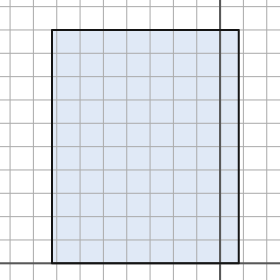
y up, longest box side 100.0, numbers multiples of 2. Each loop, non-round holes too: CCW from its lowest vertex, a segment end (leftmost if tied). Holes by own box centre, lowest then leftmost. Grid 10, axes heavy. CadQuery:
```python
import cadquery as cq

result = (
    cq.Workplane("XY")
    .moveTo(-72.0, 0.0)
    .lineTo(8.0, 0.0)
    .lineTo(8.0, 100.0)
    .lineTo(-72.0, 100.0)
    .close()
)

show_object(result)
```